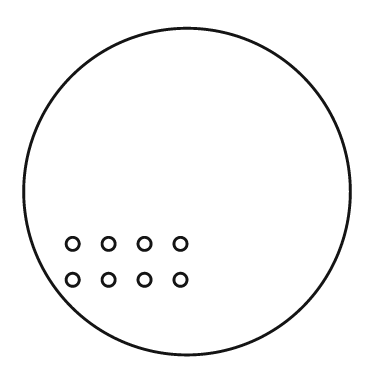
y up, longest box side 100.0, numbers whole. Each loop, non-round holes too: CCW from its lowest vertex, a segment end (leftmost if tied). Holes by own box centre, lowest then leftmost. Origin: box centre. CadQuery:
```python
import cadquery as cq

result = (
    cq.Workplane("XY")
    .moveTo(0.0, 0.0)
    .circle(50.0)
    .moveTo(-35.0, -27.0)
    .circle(2.0)
    .moveTo(-24.0, -27.0)
    .circle(2.0)
    .moveTo(-13.0, -27.0)
    .circle(2.0)
    .moveTo(-2.0, -27.0)
    .circle(2.0)
    .moveTo(-35.0, -16.0)
    .circle(2.0)
    .moveTo(-24.0, -16.0)
    .circle(2.0)
    .moveTo(-13.0, -16.0)
    .circle(2.0)
    .moveTo(-2.0, -16.0)
    .circle(2.0)
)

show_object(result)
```